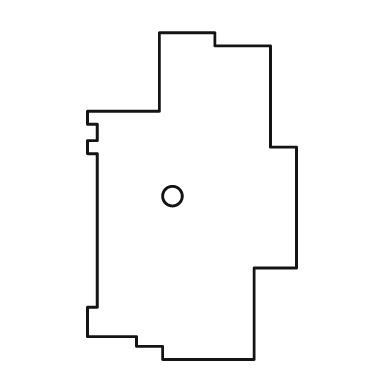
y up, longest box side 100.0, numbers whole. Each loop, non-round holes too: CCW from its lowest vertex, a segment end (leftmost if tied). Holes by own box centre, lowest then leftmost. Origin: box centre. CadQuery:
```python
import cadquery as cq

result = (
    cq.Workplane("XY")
    .moveTo(-9.0, -50.0)
    .lineTo(19.0, -50.0)
    .lineTo(19.0, -22.0)
    .lineTo(32.0, -22.0)
    .lineTo(32.0, 15.0)
    .lineTo(24.0, 15.0)
    .lineTo(24.0, 46.0)
    .lineTo(7.0, 46.0)
    .lineTo(7.0, 50.0)
    .lineTo(-10.0, 50.0)
    .lineTo(-10.0, 26.0)
    .lineTo(-32.0, 26.0)
    .lineTo(-32.0, 22.0)
    .lineTo(-29.0, 22.0)
    .lineTo(-29.0, 17.0)
    .lineTo(-32.0, 17.0)
    .lineTo(-32.0, 13.0)
    .lineTo(-29.0, 13.0)
    .lineTo(-29.0, -34.0)
    .lineTo(-32.0, -34.0)
    .lineTo(-32.0, -43.0)
    .lineTo(-17.0, -43.0)
    .lineTo(-17.0, -46.0)
    .lineTo(-9.0, -46.0)
    .close()
    .moveTo(-6.0, 0.0)
    .circle(3.0)
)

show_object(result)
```